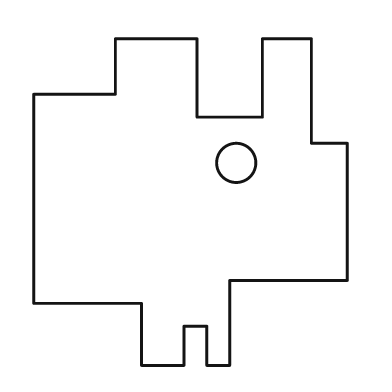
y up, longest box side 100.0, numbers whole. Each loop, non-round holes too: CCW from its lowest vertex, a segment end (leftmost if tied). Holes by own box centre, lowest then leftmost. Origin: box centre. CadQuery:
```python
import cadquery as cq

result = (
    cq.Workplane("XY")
    .moveTo(-15.0, -50.0)
    .lineTo(-2.0, -50.0)
    .lineTo(-2.0, -38.0)
    .lineTo(5.0, -38.0)
    .lineTo(5.0, -50.0)
    .lineTo(12.0, -50.0)
    .lineTo(12.0, -24.0)
    .lineTo(48.0, -24.0)
    .lineTo(48.0, 18.0)
    .lineTo(37.0, 18.0)
    .lineTo(37.0, 50.0)
    .lineTo(22.0, 50.0)
    .lineTo(22.0, 26.0)
    .lineTo(2.0, 26.0)
    .lineTo(2.0, 50.0)
    .lineTo(-23.0, 50.0)
    .lineTo(-23.0, 33.0)
    .lineTo(-48.0, 33.0)
    .lineTo(-48.0, -31.0)
    .lineTo(-15.0, -31.0)
    .close()
    .moveTo(14.0, 12.0)
    .circle(6.0)
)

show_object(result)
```